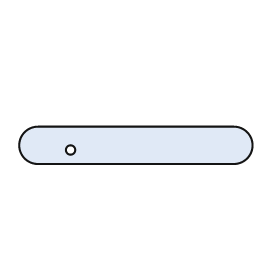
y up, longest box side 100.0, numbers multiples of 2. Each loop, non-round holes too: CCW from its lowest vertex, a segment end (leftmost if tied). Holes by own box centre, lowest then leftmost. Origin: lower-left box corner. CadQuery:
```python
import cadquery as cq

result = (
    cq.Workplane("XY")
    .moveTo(8.0, 0.0)
    .lineTo(92.0, 0.0)
    .threePointArc((100.0, 8.0), (92.0, 16.0))
    .lineTo(8.0, 16.0)
    .threePointArc((0.0, 8.0), (8.0, 0.0))
    .close()
    .moveTo(22.0, 6.0)
    .circle(2.0)
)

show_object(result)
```